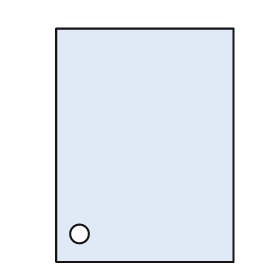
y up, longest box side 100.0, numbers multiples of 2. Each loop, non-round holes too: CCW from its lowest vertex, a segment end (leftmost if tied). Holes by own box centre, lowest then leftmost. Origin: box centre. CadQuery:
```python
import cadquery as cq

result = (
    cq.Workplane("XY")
    .moveTo(-38.0, -50.0)
    .lineTo(38.0, -50.0)
    .lineTo(38.0, 50.0)
    .lineTo(-38.0, 50.0)
    .close()
    .moveTo(-28.0, -38.0)
    .circle(4.0)
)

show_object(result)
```